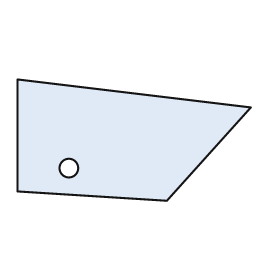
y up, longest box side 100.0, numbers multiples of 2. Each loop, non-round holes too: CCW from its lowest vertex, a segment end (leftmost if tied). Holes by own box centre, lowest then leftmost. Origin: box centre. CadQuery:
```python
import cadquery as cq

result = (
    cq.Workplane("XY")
    .moveTo(14.0, -26.0)
    .lineTo(50.0, 14.0)
    .lineTo(-50.0, 26.0)
    .lineTo(-50.0, -22.0)
    .close()
    .moveTo(-28.0, -12.0)
    .circle(4.0)
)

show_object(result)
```